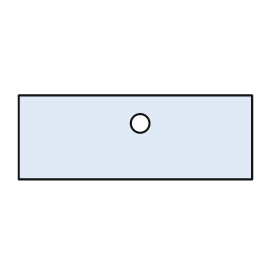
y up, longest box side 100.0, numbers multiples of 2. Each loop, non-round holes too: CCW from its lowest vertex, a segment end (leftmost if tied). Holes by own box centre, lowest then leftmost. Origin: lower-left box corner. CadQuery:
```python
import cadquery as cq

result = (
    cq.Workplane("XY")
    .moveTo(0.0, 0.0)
    .lineTo(100.0, 0.0)
    .lineTo(100.0, 36.0)
    .lineTo(0.0, 36.0)
    .close()
    .moveTo(52.0, 24.0)
    .circle(4.0)
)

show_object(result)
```